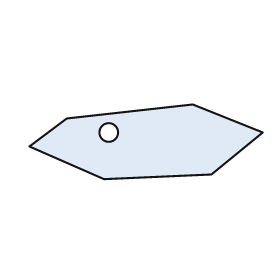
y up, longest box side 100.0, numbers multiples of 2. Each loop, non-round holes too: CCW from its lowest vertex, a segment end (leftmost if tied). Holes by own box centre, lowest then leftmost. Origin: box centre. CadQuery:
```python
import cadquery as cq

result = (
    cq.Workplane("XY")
    .moveTo(-18.0, -16.0)
    .lineTo(28.0, -14.0)
    .lineTo(50.0, 4.0)
    .lineTo(20.0, 16.0)
    .lineTo(-34.0, 10.0)
    .lineTo(-50.0, -2.0)
    .close()
    .moveTo(-16.0, 4.0)
    .circle(4.0)
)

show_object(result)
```